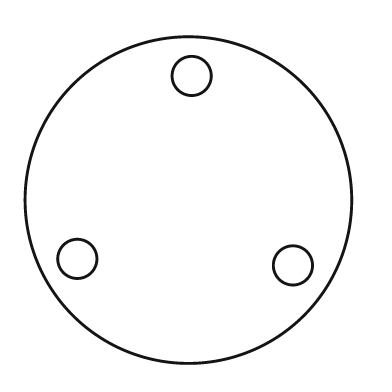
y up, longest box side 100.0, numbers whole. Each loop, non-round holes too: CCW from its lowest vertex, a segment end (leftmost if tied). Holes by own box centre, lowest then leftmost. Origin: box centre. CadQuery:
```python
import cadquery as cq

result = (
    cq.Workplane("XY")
    .moveTo(0.0, 0.0)
    .circle(50.0)
    .moveTo(32.0, -20.0)
    .circle(6.0)
    .moveTo(-34.0, -18.0)
    .circle(6.0)
    .moveTo(1.0, 38.0)
    .circle(6.0)
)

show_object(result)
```